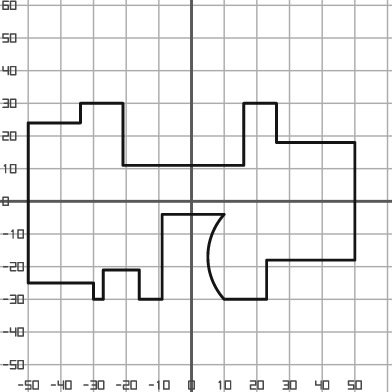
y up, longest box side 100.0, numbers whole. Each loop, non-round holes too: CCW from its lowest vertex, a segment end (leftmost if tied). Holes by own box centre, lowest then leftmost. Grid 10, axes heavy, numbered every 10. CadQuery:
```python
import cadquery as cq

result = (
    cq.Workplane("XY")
    .moveTo(-30.0, -30.0)
    .lineTo(-27.0, -30.0)
    .lineTo(-27.0, -21.0)
    .lineTo(-16.0, -21.0)
    .lineTo(-16.0, -30.0)
    .lineTo(-9.0, -30.0)
    .lineTo(-9.0, -4.0)
    .lineTo(10.0, -4.0)
    .threePointArc((5.0, -17.0), (10.0, -30.0))
    .lineTo(23.0, -30.0)
    .lineTo(23.0, -18.0)
    .lineTo(50.0, -18.0)
    .lineTo(50.0, 18.0)
    .lineTo(26.0, 18.0)
    .lineTo(26.0, 30.0)
    .lineTo(16.0, 30.0)
    .lineTo(16.0, 11.0)
    .lineTo(-21.0, 11.0)
    .lineTo(-21.0, 30.0)
    .lineTo(-34.0, 30.0)
    .lineTo(-34.0, 24.0)
    .lineTo(-50.0, 24.0)
    .lineTo(-50.0, -25.0)
    .lineTo(-30.0, -25.0)
    .close()
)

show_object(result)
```